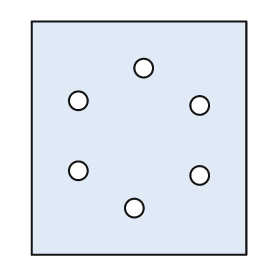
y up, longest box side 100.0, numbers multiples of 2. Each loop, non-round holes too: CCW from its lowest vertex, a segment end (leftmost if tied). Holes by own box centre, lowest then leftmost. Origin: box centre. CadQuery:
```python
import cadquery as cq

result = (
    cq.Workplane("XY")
    .moveTo(-46.0, -50.0)
    .lineTo(46.0, -50.0)
    .lineTo(46.0, 50.0)
    .lineTo(-46.0, 50.0)
    .close()
    .moveTo(-2.0, -30.0)
    .circle(4.0)
    .moveTo(26.0, -16.0)
    .circle(4.0)
    .moveTo(-26.0, -14.0)
    .circle(4.0)
    .moveTo(26.0, 14.0)
    .circle(4.0)
    .moveTo(-26.0, 16.0)
    .circle(4.0)
    .moveTo(2.0, 30.0)
    .circle(4.0)
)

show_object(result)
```